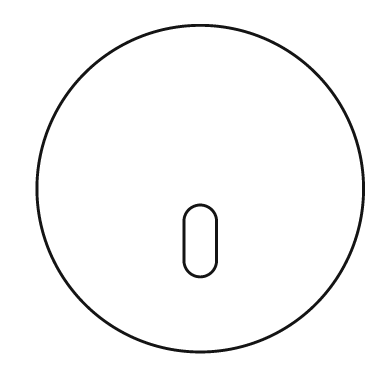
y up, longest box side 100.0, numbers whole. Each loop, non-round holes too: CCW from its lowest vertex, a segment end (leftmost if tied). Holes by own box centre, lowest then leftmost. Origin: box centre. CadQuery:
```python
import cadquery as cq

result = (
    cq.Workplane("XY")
    .moveTo(0.0, 0.0)
    .circle(50.0)
    .moveTo(-5.0, -22.0)
    .threePointArc((0.0, -27.0), (5.0, -22.0))
    .lineTo(5.0, -10.0)
    .threePointArc((0.0, -5.0), (-5.0, -10.0))
    .close()
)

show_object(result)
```